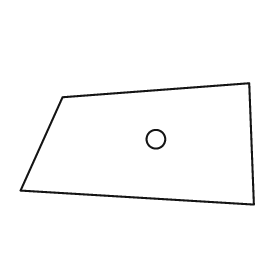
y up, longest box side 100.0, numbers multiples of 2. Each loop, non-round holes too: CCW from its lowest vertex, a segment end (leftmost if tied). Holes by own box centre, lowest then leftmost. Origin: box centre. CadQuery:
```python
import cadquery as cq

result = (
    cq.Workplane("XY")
    .moveTo(50.0, -26.0)
    .lineTo(48.0, 26.0)
    .lineTo(-32.0, 20.0)
    .lineTo(-50.0, -20.0)
    .close()
    .moveTo(8.0, 2.0)
    .circle(4.0)
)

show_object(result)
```